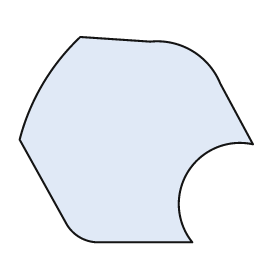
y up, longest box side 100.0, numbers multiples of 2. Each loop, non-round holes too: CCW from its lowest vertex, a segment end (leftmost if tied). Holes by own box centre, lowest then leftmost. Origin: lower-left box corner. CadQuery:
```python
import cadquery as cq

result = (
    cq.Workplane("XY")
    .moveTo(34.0, 0.0)
    .lineTo(74.0, 0.0)
    .threePointArc((72.0, 30.0), (100.0, 42.0))
    .lineTo(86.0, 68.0)
    .threePointArc((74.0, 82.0), (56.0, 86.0))
    .lineTo(26.0, 88.0)
    .threePointArc((10.0, 68.0), (0.0, 44.0))
    .lineTo(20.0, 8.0)
    .threePointArc((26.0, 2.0), (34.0, 0.0))
    .close()
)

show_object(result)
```